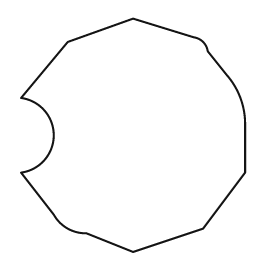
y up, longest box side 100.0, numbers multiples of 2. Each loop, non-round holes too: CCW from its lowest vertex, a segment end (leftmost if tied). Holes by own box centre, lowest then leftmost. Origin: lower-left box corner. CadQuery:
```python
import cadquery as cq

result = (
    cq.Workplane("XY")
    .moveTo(48.0, 0.0)
    .lineTo(78.0, 10.0)
    .lineTo(96.0, 34.0)
    .lineTo(96.0, 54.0)
    .threePointArc((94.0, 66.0), (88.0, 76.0))
    .lineTo(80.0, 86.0)
    .threePointArc((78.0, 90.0), (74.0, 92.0))
    .lineTo(48.0, 100.0)
    .lineTo(20.0, 90.0)
    .lineTo(0.0, 66.0)
    .threePointArc((14.0, 50.0), (0.0, 34.0))
    .lineTo(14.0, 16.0)
    .threePointArc((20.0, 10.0), (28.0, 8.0))
    .close()
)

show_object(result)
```